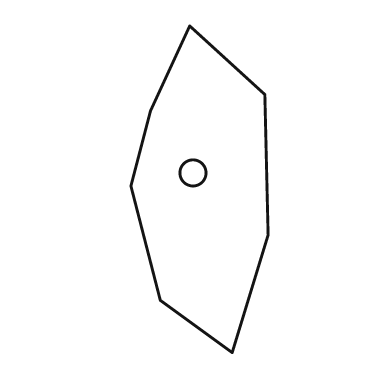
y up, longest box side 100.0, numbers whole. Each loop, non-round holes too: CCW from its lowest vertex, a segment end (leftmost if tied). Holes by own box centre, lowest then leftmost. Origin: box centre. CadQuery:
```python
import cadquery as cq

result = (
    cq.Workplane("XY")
    .moveTo(10.0, -50.0)
    .lineTo(21.0, -14.0)
    .lineTo(20.0, 29.0)
    .lineTo(-3.0, 50.0)
    .lineTo(-15.0, 24.0)
    .lineTo(-21.0, 1.0)
    .lineTo(-12.0, -34.0)
    .close()
    .moveTo(-2.0, 5.0)
    .circle(4.0)
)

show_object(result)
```